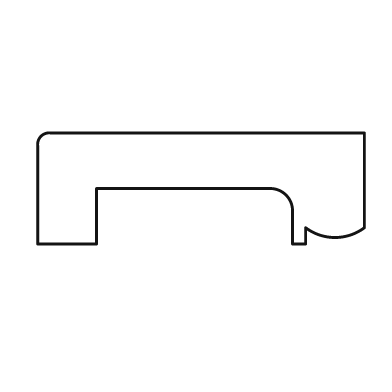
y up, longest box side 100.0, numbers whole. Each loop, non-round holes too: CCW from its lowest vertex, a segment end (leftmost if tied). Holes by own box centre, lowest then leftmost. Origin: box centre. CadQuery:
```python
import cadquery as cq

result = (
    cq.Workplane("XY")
    .moveTo(-50.0, -17.0)
    .lineTo(-32.0, -17.0)
    .lineTo(-32.0, 0.0)
    .lineTo(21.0, 0.0)
    .threePointArc((26.0, -2.0), (28.0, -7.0))
    .lineTo(28.0, -17.0)
    .lineTo(32.0, -17.0)
    .lineTo(32.0, -12.0)
    .threePointArc((41.0, -15.0), (50.0, -12.0))
    .lineTo(50.0, 17.0)
    .lineTo(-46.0, 17.0)
    .threePointArc((-49.0, 16.0), (-50.0, 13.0))
    .close()
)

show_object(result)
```